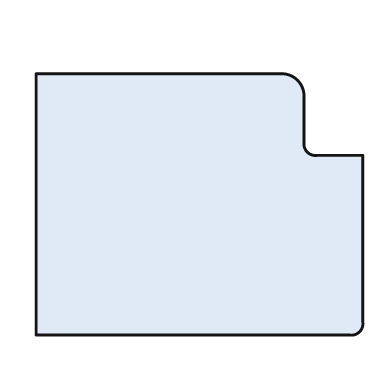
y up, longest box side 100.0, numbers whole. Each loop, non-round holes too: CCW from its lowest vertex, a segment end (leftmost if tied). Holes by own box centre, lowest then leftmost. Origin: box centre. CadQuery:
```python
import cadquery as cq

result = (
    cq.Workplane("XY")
    .moveTo(-50.0, -40.0)
    .lineTo(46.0, -40.0)
    .threePointArc((49.0, -39.0), (50.0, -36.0))
    .lineTo(50.0, 15.0)
    .lineTo(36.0, 15.0)
    .threePointArc((33.0, 16.0), (32.0, 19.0))
    .lineTo(32.0, 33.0)
    .threePointArc((30.0, 38.0), (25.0, 40.0))
    .lineTo(-50.0, 40.0)
    .close()
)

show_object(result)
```